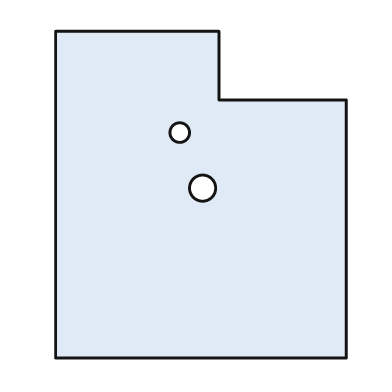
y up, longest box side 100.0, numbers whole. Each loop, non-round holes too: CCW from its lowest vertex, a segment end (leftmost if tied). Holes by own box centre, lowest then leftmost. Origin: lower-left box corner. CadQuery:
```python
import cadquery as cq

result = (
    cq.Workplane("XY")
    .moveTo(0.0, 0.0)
    .lineTo(89.0, 0.0)
    .lineTo(89.0, 79.0)
    .lineTo(50.0, 79.0)
    .lineTo(50.0, 100.0)
    .lineTo(0.0, 100.0)
    .close()
    .moveTo(45.0, 52.0)
    .circle(4.0)
    .moveTo(38.0, 69.0)
    .circle(3.0)
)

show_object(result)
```